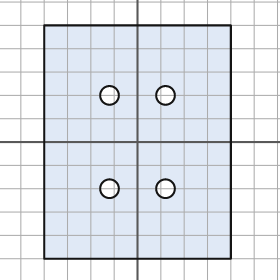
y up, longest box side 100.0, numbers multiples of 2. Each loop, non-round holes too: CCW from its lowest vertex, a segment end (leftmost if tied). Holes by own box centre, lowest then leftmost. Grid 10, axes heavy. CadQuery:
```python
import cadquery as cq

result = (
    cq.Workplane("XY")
    .moveTo(-40.0, -50.0)
    .lineTo(40.0, -50.0)
    .lineTo(40.0, 50.0)
    .lineTo(-40.0, 50.0)
    .close()
    .moveTo(-12.0, -20.0)
    .circle(4.0)
    .moveTo(12.0, -20.0)
    .circle(4.0)
    .moveTo(-12.0, 20.0)
    .circle(4.0)
    .moveTo(12.0, 20.0)
    .circle(4.0)
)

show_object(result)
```